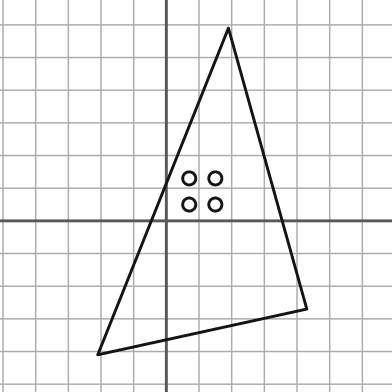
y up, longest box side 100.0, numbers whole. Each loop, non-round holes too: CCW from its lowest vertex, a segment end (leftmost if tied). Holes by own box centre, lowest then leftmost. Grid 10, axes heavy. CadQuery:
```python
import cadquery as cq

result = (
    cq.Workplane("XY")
    .moveTo(-21.0, -41.0)
    .lineTo(43.0, -27.0)
    .lineTo(19.0, 59.0)
    .close()
    .moveTo(7.0, 5.0)
    .circle(2.0)
    .moveTo(15.0, 5.0)
    .circle(2.0)
    .moveTo(7.0, 13.0)
    .circle(2.0)
    .moveTo(15.0, 13.0)
    .circle(2.0)
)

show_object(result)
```